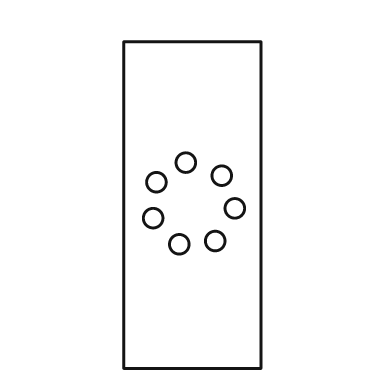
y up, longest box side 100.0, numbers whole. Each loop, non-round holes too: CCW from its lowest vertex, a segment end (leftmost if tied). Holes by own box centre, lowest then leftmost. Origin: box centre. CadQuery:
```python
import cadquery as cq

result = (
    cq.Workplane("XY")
    .moveTo(-21.0, -50.0)
    .lineTo(21.0, -50.0)
    .lineTo(21.0, 50.0)
    .lineTo(-21.0, 50.0)
    .close()
    .moveTo(-4.0, -12.0)
    .circle(3.0)
    .moveTo(7.0, -11.0)
    .circle(3.0)
    .moveTo(-12.0, -4.0)
    .circle(3.0)
    .moveTo(13.0, -1.0)
    .circle(3.0)
    .moveTo(-11.0, 7.0)
    .circle(3.0)
    .moveTo(9.0, 9.0)
    .circle(3.0)
    .moveTo(-2.0, 13.0)
    .circle(3.0)
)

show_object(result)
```